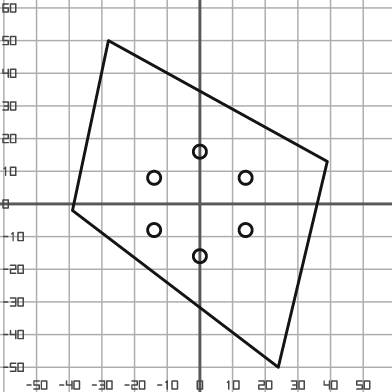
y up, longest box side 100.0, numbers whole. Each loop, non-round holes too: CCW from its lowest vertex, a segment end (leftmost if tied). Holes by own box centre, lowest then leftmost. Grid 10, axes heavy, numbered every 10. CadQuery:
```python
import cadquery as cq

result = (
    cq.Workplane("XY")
    .moveTo(24.0, -50.0)
    .lineTo(39.0, 13.0)
    .lineTo(-28.0, 50.0)
    .lineTo(-39.0, -2.0)
    .close()
    .moveTo(0.0, -16.0)
    .circle(2.0)
    .moveTo(-14.0, -8.0)
    .circle(2.0)
    .moveTo(14.0, -8.0)
    .circle(2.0)
    .moveTo(-14.0, 8.0)
    .circle(2.0)
    .moveTo(14.0, 8.0)
    .circle(2.0)
    .moveTo(0.0, 16.0)
    .circle(2.0)
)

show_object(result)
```